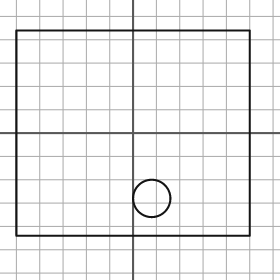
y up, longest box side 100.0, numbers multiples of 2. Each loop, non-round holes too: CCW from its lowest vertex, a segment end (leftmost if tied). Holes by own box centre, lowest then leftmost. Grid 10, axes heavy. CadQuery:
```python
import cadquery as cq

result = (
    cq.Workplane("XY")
    .moveTo(-50.0, -44.0)
    .lineTo(50.0, -44.0)
    .lineTo(50.0, 44.0)
    .lineTo(-50.0, 44.0)
    .close()
    .moveTo(8.0, -28.0)
    .circle(8.0)
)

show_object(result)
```